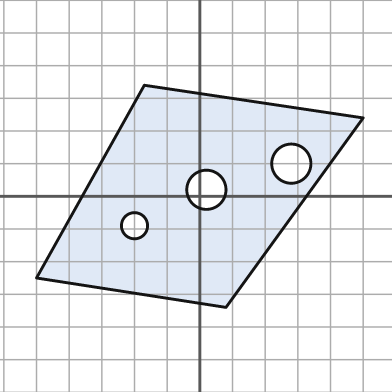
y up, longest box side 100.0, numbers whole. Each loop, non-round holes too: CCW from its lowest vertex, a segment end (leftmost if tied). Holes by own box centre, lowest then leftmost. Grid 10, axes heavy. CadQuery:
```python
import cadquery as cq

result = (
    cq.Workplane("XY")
    .moveTo(8.0, -34.0)
    .lineTo(50.0, 24.0)
    .lineTo(-17.0, 34.0)
    .lineTo(-50.0, -25.0)
    .close()
    .moveTo(-20.0, -9.0)
    .circle(4.0)
    .moveTo(2.0, 2.0)
    .circle(6.0)
    .moveTo(28.0, 10.0)
    .circle(6.0)
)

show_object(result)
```